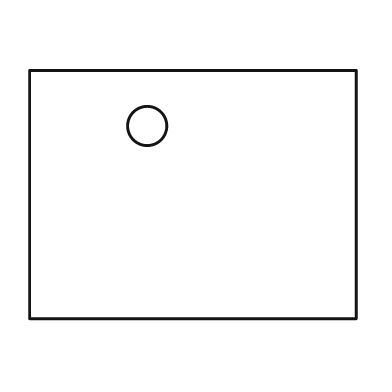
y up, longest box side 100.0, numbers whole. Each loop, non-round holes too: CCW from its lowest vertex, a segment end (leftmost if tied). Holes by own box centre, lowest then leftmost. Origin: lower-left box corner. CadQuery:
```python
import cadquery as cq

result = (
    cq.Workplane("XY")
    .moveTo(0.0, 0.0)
    .lineTo(100.0, 0.0)
    .lineTo(100.0, 76.0)
    .lineTo(0.0, 76.0)
    .close()
    .moveTo(36.0, 59.0)
    .circle(6.0)
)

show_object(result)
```